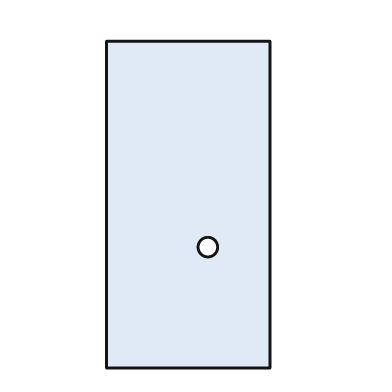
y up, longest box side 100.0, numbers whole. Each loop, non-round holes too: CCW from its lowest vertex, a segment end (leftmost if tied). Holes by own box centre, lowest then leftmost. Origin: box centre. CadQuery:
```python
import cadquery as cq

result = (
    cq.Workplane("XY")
    .moveTo(-25.0, -50.0)
    .lineTo(25.0, -50.0)
    .lineTo(25.0, 50.0)
    .lineTo(-25.0, 50.0)
    .close()
    .moveTo(6.0, -13.0)
    .circle(3.0)
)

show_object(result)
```